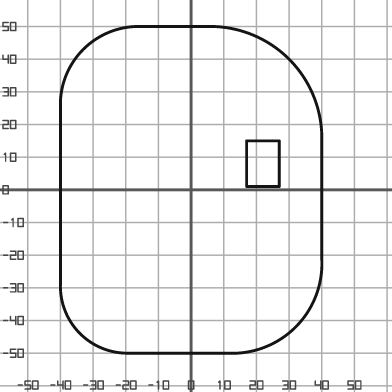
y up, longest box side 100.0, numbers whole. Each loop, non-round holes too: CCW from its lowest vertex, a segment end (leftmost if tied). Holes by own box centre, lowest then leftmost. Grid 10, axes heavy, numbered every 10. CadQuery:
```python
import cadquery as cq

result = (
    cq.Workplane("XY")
    .moveTo(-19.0, -50.0)
    .lineTo(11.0, -50.0)
    .threePointArc((32.0, -42.0), (40.0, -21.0))
    .lineTo(40.0, 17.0)
    .threePointArc((30.0, 40.0), (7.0, 50.0))
    .lineTo(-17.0, 50.0)
    .threePointArc((-33.0, 43.0), (-40.0, 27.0))
    .lineTo(-40.0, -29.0)
    .threePointArc((-34.0, -44.0), (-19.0, -50.0))
    .close()
    .moveTo(17.0, 1.0)
    .lineTo(27.0, 1.0)
    .lineTo(27.0, 15.0)
    .lineTo(17.0, 15.0)
    .close()
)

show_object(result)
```